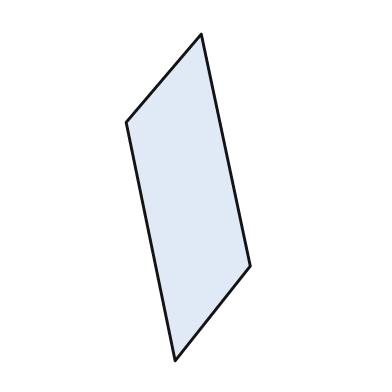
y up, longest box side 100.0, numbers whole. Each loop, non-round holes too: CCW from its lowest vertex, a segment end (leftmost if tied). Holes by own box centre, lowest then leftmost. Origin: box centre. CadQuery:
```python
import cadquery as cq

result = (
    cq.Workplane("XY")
    .moveTo(-4.0, -50.0)
    .lineTo(19.0, -21.0)
    .lineTo(4.0, 50.0)
    .lineTo(-19.0, 23.0)
    .close()
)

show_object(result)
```